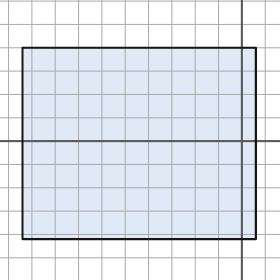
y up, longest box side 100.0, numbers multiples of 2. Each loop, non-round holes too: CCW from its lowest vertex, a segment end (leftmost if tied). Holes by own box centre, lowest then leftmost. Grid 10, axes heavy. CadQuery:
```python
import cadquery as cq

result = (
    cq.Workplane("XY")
    .moveTo(-94.0, -42.0)
    .lineTo(6.0, -42.0)
    .lineTo(6.0, 40.0)
    .lineTo(-94.0, 40.0)
    .close()
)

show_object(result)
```